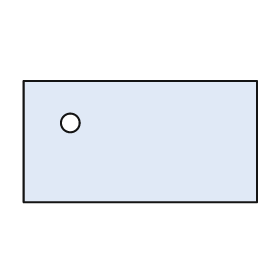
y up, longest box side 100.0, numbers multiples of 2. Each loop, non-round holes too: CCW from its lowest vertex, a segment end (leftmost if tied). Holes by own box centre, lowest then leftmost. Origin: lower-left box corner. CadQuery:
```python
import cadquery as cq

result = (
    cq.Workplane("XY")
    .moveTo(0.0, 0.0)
    .lineTo(100.0, 0.0)
    .lineTo(100.0, 52.0)
    .lineTo(0.0, 52.0)
    .close()
    .moveTo(20.0, 34.0)
    .circle(4.0)
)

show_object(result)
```